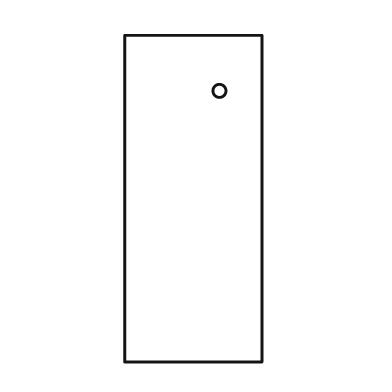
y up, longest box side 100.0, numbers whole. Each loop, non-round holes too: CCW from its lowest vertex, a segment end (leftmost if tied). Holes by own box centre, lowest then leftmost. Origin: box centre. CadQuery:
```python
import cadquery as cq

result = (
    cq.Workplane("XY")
    .moveTo(-21.0, -50.0)
    .lineTo(21.0, -50.0)
    .lineTo(21.0, 50.0)
    .lineTo(-21.0, 50.0)
    .close()
    .moveTo(8.0, 33.0)
    .circle(2.0)
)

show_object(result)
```